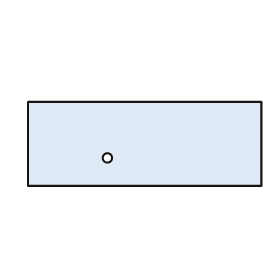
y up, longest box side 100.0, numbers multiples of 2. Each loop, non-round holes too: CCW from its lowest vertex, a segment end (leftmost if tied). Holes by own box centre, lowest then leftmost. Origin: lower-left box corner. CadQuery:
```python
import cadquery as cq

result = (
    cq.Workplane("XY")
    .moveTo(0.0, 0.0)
    .lineTo(100.0, 0.0)
    .lineTo(100.0, 36.0)
    .lineTo(0.0, 36.0)
    .close()
    .moveTo(34.0, 12.0)
    .circle(2.0)
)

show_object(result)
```